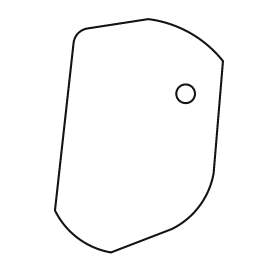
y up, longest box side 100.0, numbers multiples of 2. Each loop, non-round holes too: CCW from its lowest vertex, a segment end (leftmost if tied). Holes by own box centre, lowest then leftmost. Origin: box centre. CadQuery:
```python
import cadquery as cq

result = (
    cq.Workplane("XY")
    .moveTo(-12.0, -50.0)
    .lineTo(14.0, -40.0)
    .threePointArc((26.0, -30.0), (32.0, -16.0))
    .lineTo(36.0, 32.0)
    .threePointArc((22.0, 44.0), (4.0, 50.0))
    .lineTo(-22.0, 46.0)
    .threePointArc((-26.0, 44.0), (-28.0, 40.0))
    .lineTo(-36.0, -32.0)
    .threePointArc((-26.0, -44.0), (-12.0, -50.0))
    .close()
    .moveTo(20.0, 18.0)
    .circle(4.0)
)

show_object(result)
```